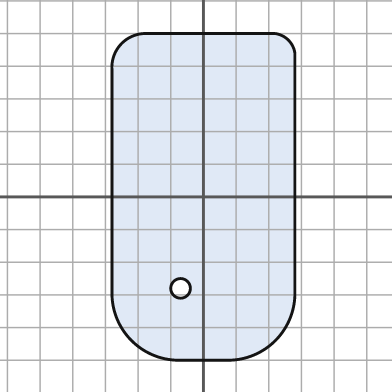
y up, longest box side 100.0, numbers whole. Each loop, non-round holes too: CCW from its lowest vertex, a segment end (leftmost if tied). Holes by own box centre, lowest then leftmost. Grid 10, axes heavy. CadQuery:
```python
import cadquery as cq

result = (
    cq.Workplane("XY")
    .moveTo(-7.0, -50.0)
    .lineTo(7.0, -50.0)
    .threePointArc((22.0, -44.0), (28.0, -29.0))
    .lineTo(28.0, 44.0)
    .threePointArc((26.0, 48.0), (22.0, 50.0))
    .lineTo(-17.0, 50.0)
    .threePointArc((-25.0, 47.0), (-28.0, 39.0))
    .lineTo(-28.0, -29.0)
    .threePointArc((-22.0, -44.0), (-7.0, -50.0))
    .close()
    .moveTo(-7.0, -28.0)
    .circle(3.0)
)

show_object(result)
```